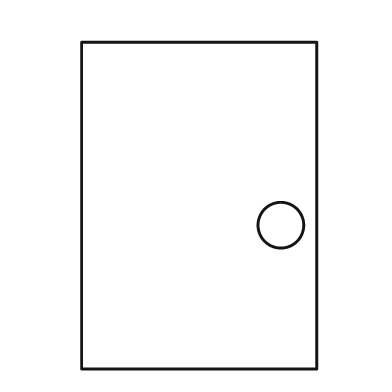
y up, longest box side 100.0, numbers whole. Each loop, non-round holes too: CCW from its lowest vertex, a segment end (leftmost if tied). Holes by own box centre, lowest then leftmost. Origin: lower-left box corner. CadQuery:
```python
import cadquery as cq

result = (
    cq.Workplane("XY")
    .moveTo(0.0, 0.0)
    .lineTo(72.0, 0.0)
    .lineTo(72.0, 100.0)
    .lineTo(0.0, 100.0)
    .close()
    .moveTo(61.0, 44.0)
    .circle(7.0)
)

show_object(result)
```